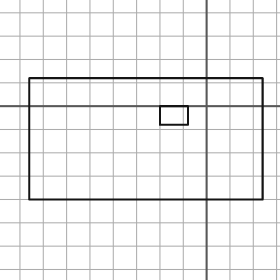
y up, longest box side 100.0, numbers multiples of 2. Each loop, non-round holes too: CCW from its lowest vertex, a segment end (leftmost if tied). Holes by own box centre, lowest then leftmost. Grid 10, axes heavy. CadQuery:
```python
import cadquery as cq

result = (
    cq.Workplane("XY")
    .moveTo(-76.0, -40.0)
    .lineTo(24.0, -40.0)
    .lineTo(24.0, 12.0)
    .lineTo(-76.0, 12.0)
    .close()
    .moveTo(-20.0, -8.0)
    .lineTo(-8.0, -8.0)
    .lineTo(-8.0, 0.0)
    .lineTo(-20.0, 0.0)
    .close()
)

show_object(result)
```